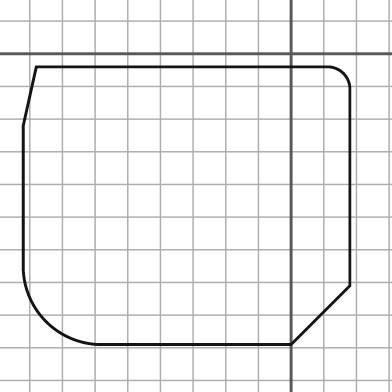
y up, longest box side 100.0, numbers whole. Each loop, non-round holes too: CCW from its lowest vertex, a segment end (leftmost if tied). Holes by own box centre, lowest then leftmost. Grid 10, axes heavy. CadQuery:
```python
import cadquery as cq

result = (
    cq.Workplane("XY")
    .moveTo(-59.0, -89.0)
    .lineTo(0.0, -89.0)
    .lineTo(18.0, -71.0)
    .lineTo(18.0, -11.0)
    .threePointArc((16.0, -6.0), (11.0, -4.0))
    .lineTo(-78.0, -4.0)
    .lineTo(-82.0, -22.0)
    .lineTo(-82.0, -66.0)
    .threePointArc((-75.0, -82.0), (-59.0, -89.0))
    .close()
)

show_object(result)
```